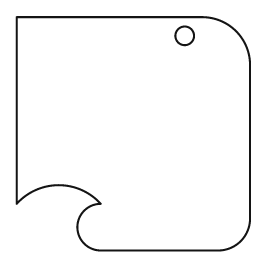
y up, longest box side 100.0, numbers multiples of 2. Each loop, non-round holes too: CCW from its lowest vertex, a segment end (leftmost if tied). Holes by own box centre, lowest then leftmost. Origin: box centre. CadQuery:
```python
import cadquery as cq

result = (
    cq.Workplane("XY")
    .moveTo(-14.0, -50.0)
    .lineTo(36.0, -50.0)
    .threePointArc((46.0, -46.0), (50.0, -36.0))
    .lineTo(50.0, 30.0)
    .threePointArc((44.0, 44.0), (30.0, 50.0))
    .lineTo(-50.0, 50.0)
    .lineTo(-50.0, -30.0)
    .threePointArc((-32.0, -22.0), (-14.0, -30.0))
    .threePointArc((-24.0, -40.0), (-14.0, -50.0))
    .close()
    .moveTo(22.0, 42.0)
    .circle(4.0)
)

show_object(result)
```